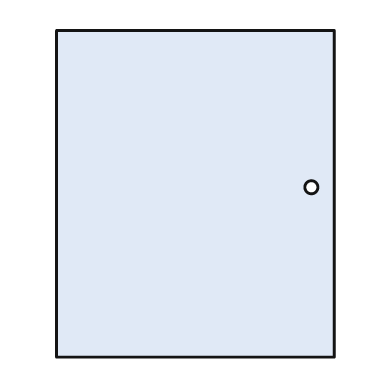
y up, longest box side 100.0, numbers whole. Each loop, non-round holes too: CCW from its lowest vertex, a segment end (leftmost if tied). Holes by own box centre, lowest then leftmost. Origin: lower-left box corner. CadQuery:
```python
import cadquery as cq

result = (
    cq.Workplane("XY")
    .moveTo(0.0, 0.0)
    .lineTo(85.0, 0.0)
    .lineTo(85.0, 100.0)
    .lineTo(0.0, 100.0)
    .close()
    .moveTo(78.0, 52.0)
    .circle(2.0)
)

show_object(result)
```